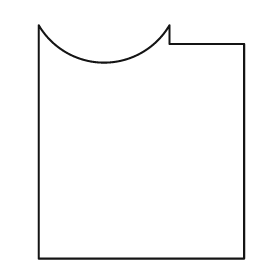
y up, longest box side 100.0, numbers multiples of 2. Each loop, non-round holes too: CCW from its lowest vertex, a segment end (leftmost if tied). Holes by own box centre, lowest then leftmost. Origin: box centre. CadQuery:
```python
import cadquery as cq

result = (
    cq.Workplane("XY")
    .moveTo(-44.0, -50.0)
    .lineTo(44.0, -50.0)
    .lineTo(44.0, 42.0)
    .lineTo(12.0, 42.0)
    .lineTo(12.0, 50.0)
    .threePointArc((-16.0, 34.0), (-44.0, 50.0))
    .close()
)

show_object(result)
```